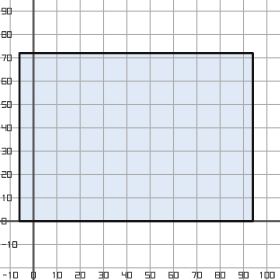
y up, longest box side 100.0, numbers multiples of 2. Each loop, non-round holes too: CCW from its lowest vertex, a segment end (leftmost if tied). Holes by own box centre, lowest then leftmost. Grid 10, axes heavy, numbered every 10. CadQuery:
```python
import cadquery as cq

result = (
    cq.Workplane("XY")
    .moveTo(-6.0, 0.0)
    .lineTo(94.0, 0.0)
    .lineTo(94.0, 72.0)
    .lineTo(-6.0, 72.0)
    .close()
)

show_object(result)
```